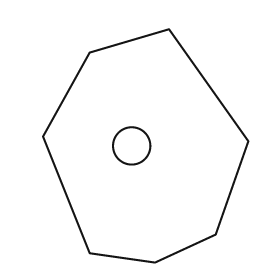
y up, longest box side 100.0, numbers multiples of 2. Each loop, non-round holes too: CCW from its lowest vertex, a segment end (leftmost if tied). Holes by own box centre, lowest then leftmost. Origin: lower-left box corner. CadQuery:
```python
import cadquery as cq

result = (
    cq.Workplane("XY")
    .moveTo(48.0, 0.0)
    .lineTo(74.0, 12.0)
    .lineTo(88.0, 52.0)
    .lineTo(54.0, 100.0)
    .lineTo(20.0, 90.0)
    .lineTo(0.0, 54.0)
    .lineTo(20.0, 4.0)
    .close()
    .moveTo(38.0, 50.0)
    .circle(8.0)
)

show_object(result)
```